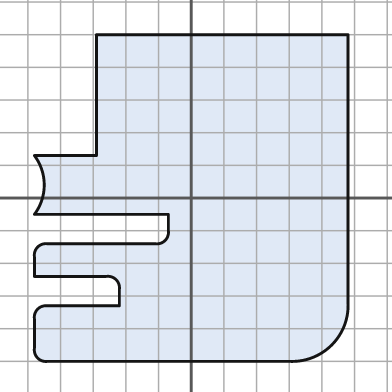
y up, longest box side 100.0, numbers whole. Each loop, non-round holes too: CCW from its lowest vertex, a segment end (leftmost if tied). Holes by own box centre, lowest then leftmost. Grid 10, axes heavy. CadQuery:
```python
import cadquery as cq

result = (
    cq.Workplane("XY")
    .moveTo(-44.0, -50.0)
    .lineTo(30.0, -50.0)
    .threePointArc((43.0, -45.0), (48.0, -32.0))
    .lineTo(48.0, 50.0)
    .lineTo(-29.0, 50.0)
    .lineTo(-29.0, 13.0)
    .lineTo(-48.0, 13.0)
    .threePointArc((-45.0, 4.0), (-48.0, -5.0))
    .lineTo(-7.0, -5.0)
    .lineTo(-7.0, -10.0)
    .threePointArc((-8.0, -13.0), (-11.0, -14.0))
    .lineTo(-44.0, -14.0)
    .threePointArc((-47.0, -15.0), (-48.0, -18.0))
    .lineTo(-48.0, -24.0)
    .lineTo(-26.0, -24.0)
    .threePointArc((-23.0, -25.0), (-22.0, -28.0))
    .lineTo(-22.0, -33.0)
    .lineTo(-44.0, -33.0)
    .threePointArc((-47.0, -34.0), (-48.0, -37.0))
    .lineTo(-48.0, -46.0)
    .threePointArc((-47.0, -49.0), (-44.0, -50.0))
    .close()
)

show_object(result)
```